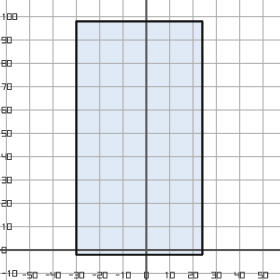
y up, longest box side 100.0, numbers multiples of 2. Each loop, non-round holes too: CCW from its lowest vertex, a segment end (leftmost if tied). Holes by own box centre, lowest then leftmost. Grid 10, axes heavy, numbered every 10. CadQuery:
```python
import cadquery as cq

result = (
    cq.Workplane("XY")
    .moveTo(-30.0, -2.0)
    .lineTo(24.0, -2.0)
    .lineTo(24.0, 98.0)
    .lineTo(-30.0, 98.0)
    .close()
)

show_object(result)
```